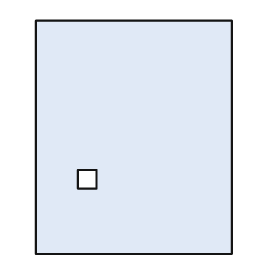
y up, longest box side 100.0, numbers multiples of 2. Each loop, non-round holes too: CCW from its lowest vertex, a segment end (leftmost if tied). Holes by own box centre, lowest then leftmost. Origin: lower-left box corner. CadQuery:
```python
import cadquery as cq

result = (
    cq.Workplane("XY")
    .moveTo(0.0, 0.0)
    .lineTo(84.0, 0.0)
    .lineTo(84.0, 100.0)
    .lineTo(0.0, 100.0)
    .close()
    .moveTo(18.0, 28.0)
    .lineTo(26.0, 28.0)
    .lineTo(26.0, 36.0)
    .lineTo(18.0, 36.0)
    .close()
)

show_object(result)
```